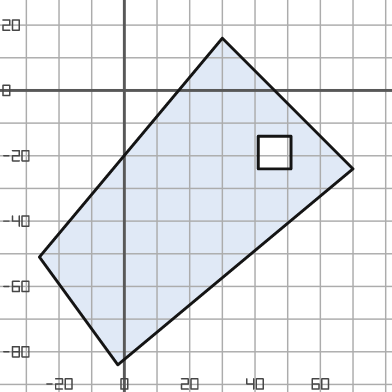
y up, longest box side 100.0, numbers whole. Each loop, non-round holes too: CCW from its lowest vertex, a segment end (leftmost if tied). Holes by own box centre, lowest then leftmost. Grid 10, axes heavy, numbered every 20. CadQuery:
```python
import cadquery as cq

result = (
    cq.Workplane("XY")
    .moveTo(-2.0, -84.0)
    .lineTo(70.0, -24.0)
    .lineTo(30.0, 16.0)
    .lineTo(-26.0, -51.0)
    .close()
    .moveTo(41.0, -24.0)
    .lineTo(51.0, -24.0)
    .lineTo(51.0, -14.0)
    .lineTo(41.0, -14.0)
    .close()
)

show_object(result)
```